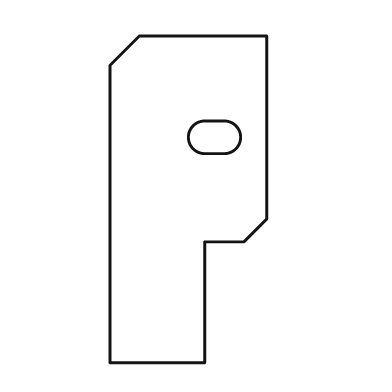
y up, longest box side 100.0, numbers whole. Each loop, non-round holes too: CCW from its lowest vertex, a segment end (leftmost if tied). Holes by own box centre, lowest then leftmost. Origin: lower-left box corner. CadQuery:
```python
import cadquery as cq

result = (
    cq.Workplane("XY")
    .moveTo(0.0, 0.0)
    .lineTo(29.0, 0.0)
    .lineTo(29.0, 37.0)
    .lineTo(41.0, 37.0)
    .lineTo(48.0, 44.0)
    .lineTo(48.0, 100.0)
    .lineTo(9.0, 100.0)
    .lineTo(0.0, 91.0)
    .close()
    .moveTo(29.0, 64.0)
    .lineTo(35.0, 64.0)
    .threePointArc((40.0, 69.0), (35.0, 74.0))
    .lineTo(29.0, 74.0)
    .threePointArc((24.0, 69.0), (29.0, 64.0))
    .close()
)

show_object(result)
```